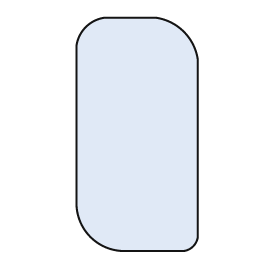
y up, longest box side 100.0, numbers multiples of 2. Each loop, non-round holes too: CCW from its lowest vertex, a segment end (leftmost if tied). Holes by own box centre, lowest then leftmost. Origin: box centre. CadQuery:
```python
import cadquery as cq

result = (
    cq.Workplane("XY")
    .moveTo(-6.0, -50.0)
    .lineTo(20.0, -50.0)
    .threePointArc((24.0, -48.0), (26.0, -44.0))
    .lineTo(26.0, 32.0)
    .threePointArc((20.0, 44.0), (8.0, 50.0))
    .lineTo(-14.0, 50.0)
    .threePointArc((-22.0, 46.0), (-26.0, 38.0))
    .lineTo(-26.0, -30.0)
    .threePointArc((-20.0, -44.0), (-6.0, -50.0))
    .close()
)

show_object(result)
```